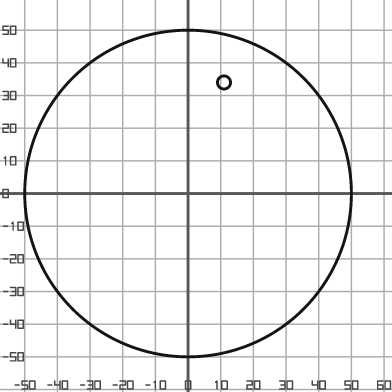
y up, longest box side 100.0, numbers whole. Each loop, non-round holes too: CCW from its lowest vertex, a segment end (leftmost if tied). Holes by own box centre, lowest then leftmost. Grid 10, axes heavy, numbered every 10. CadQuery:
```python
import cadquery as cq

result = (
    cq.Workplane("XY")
    .moveTo(0.0, 0.0)
    .circle(50.0)
    .moveTo(11.0, 34.0)
    .circle(2.0)
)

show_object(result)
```